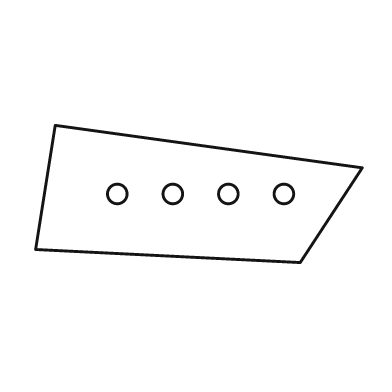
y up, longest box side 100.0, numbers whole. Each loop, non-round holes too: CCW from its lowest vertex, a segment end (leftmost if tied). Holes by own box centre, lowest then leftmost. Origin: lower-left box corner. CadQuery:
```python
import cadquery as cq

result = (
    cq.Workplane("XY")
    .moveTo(81.0, 0.0)
    .lineTo(100.0, 29.0)
    .lineTo(6.0, 42.0)
    .lineTo(0.0, 4.0)
    .close()
    .moveTo(25.0, 21.0)
    .circle(3.0)
    .moveTo(42.0, 21.0)
    .circle(3.0)
    .moveTo(59.0, 21.0)
    .circle(3.0)
    .moveTo(76.0, 21.0)
    .circle(3.0)
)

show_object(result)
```